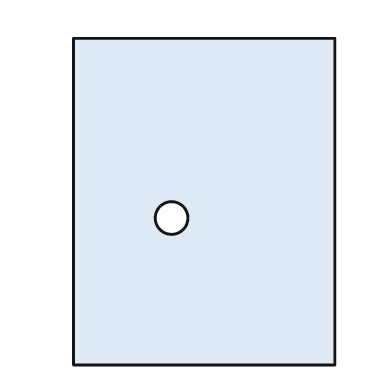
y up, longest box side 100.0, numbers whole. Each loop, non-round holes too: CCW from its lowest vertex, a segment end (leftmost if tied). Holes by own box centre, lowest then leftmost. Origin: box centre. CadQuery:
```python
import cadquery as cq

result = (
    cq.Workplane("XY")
    .moveTo(-40.0, -50.0)
    .lineTo(40.0, -50.0)
    .lineTo(40.0, 50.0)
    .lineTo(-40.0, 50.0)
    .close()
    .moveTo(-10.0, -5.0)
    .circle(5.0)
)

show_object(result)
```